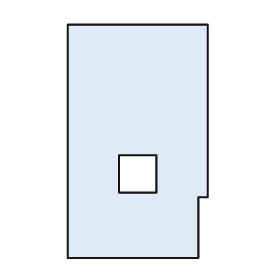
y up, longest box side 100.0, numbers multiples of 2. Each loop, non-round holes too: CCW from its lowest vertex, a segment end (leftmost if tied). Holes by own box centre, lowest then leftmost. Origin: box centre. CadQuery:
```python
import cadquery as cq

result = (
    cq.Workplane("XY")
    .moveTo(-30.0, -50.0)
    .lineTo(26.0, -50.0)
    .lineTo(26.0, -24.0)
    .lineTo(30.0, -24.0)
    .lineTo(30.0, 50.0)
    .lineTo(-30.0, 50.0)
    .close()
    .moveTo(-8.0, -22.0)
    .lineTo(8.0, -22.0)
    .lineTo(8.0, -6.0)
    .lineTo(-8.0, -6.0)
    .close()
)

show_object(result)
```